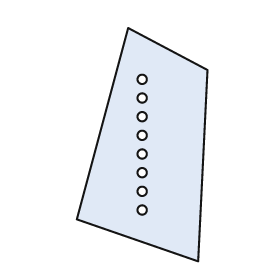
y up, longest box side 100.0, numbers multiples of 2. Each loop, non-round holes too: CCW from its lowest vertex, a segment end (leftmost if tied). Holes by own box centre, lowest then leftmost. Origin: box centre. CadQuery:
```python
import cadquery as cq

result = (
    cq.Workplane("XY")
    .moveTo(24.0, -50.0)
    .lineTo(28.0, 32.0)
    .lineTo(-6.0, 50.0)
    .lineTo(-28.0, -32.0)
    .close()
    .moveTo(0.0, -28.0)
    .circle(2.0)
    .moveTo(0.0, -20.0)
    .circle(2.0)
    .moveTo(0.0, -12.0)
    .circle(2.0)
    .moveTo(0.0, -4.0)
    .circle(2.0)
    .moveTo(0.0, 4.0)
    .circle(2.0)
    .moveTo(0.0, 12.0)
    .circle(2.0)
    .moveTo(0.0, 20.0)
    .circle(2.0)
    .moveTo(0.0, 28.0)
    .circle(2.0)
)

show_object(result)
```